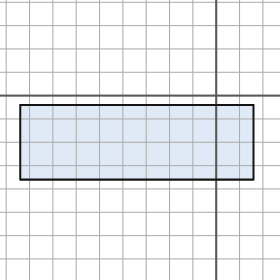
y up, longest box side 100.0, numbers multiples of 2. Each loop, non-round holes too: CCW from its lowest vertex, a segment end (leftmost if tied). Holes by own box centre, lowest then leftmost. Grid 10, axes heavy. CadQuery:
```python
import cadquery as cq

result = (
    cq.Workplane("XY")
    .moveTo(-84.0, -36.0)
    .lineTo(16.0, -36.0)
    .lineTo(16.0, -4.0)
    .lineTo(-84.0, -4.0)
    .close()
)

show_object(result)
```